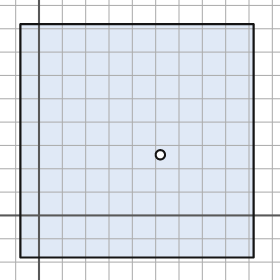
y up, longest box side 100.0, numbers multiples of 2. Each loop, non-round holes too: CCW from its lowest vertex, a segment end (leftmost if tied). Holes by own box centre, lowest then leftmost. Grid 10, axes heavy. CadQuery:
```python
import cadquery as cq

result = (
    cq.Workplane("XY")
    .moveTo(-8.0, -18.0)
    .lineTo(92.0, -18.0)
    .lineTo(92.0, 82.0)
    .lineTo(-8.0, 82.0)
    .close()
    .moveTo(52.0, 26.0)
    .circle(2.0)
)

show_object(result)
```